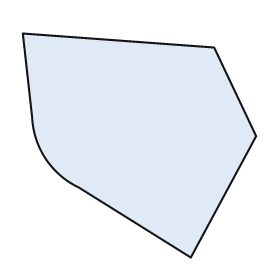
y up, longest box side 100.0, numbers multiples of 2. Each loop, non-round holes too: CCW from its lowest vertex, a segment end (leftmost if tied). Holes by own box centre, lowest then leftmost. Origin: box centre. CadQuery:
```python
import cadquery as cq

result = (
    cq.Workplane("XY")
    .moveTo(22.0, -48.0)
    .lineTo(50.0, 4.0)
    .lineTo(32.0, 42.0)
    .lineTo(-50.0, 48.0)
    .lineTo(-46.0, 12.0)
    .threePointArc((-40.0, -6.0), (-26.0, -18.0))
    .close()
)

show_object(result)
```